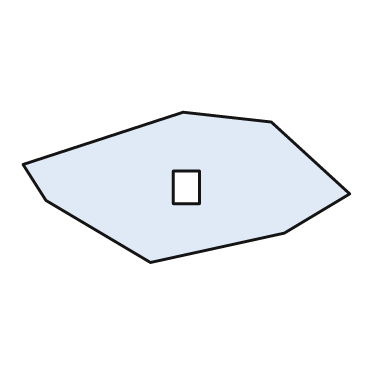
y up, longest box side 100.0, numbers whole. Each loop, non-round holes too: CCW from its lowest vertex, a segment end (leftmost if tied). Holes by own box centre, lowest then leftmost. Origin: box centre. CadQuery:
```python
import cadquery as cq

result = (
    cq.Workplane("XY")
    .moveTo(-11.0, -23.0)
    .lineTo(30.0, -14.0)
    .lineTo(50.0, -2.0)
    .lineTo(26.0, 20.0)
    .lineTo(-1.0, 23.0)
    .lineTo(-50.0, 7.0)
    .lineTo(-43.0, -4.0)
    .close()
    .moveTo(-4.0, -5.0)
    .lineTo(4.0, -5.0)
    .lineTo(4.0, 5.0)
    .lineTo(-4.0, 5.0)
    .close()
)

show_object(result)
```